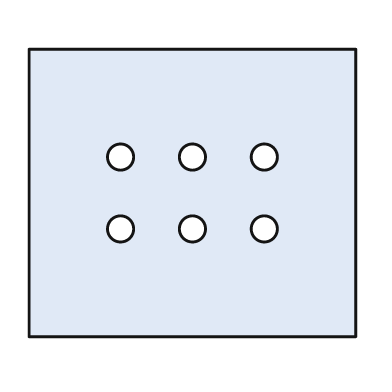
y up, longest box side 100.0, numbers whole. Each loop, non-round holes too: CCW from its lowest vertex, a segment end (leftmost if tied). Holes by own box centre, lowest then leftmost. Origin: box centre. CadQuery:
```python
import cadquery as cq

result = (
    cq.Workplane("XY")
    .moveTo(-50.0, -44.0)
    .lineTo(50.0, -44.0)
    .lineTo(50.0, 44.0)
    .lineTo(-50.0, 44.0)
    .close()
    .moveTo(-22.0, -11.0)
    .circle(4.0)
    .moveTo(0.0, -11.0)
    .circle(4.0)
    .moveTo(22.0, -11.0)
    .circle(4.0)
    .moveTo(-22.0, 11.0)
    .circle(4.0)
    .moveTo(0.0, 11.0)
    .circle(4.0)
    .moveTo(22.0, 11.0)
    .circle(4.0)
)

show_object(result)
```